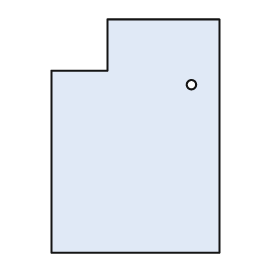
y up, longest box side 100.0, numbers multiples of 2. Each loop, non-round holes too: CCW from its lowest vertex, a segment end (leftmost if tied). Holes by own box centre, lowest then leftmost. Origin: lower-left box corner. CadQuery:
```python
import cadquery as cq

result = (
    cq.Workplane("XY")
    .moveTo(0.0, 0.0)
    .lineTo(72.0, 0.0)
    .lineTo(72.0, 100.0)
    .lineTo(24.0, 100.0)
    .lineTo(24.0, 78.0)
    .lineTo(0.0, 78.0)
    .close()
    .moveTo(60.0, 72.0)
    .circle(2.0)
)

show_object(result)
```